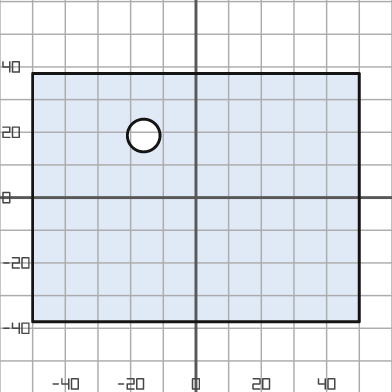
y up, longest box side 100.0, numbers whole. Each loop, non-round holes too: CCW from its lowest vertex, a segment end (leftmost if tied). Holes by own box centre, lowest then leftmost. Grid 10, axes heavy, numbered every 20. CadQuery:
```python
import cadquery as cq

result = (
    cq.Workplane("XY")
    .moveTo(-50.0, -38.0)
    .lineTo(50.0, -38.0)
    .lineTo(50.0, 38.0)
    .lineTo(-50.0, 38.0)
    .close()
    .moveTo(-16.0, 19.0)
    .circle(5.0)
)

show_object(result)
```